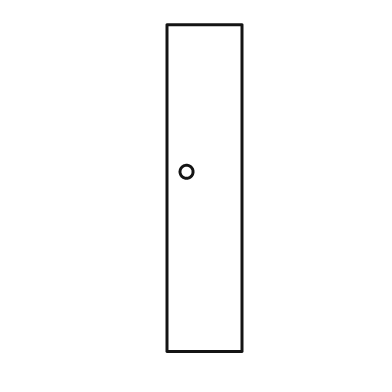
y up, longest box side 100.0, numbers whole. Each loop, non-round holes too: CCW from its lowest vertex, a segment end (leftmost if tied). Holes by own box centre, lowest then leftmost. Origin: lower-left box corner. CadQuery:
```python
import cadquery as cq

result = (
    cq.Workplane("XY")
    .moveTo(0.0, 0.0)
    .lineTo(23.0, 0.0)
    .lineTo(23.0, 100.0)
    .lineTo(0.0, 100.0)
    .close()
    .moveTo(6.0, 55.0)
    .circle(2.0)
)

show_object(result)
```